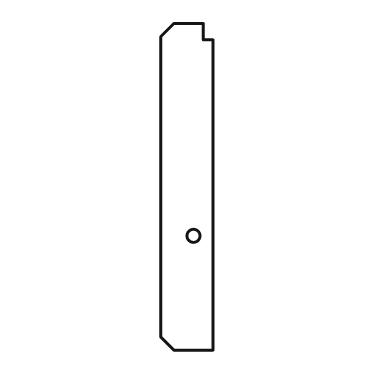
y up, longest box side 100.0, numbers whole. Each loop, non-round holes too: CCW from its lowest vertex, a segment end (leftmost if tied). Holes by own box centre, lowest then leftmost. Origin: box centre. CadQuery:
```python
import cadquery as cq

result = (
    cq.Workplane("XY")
    .moveTo(-4.0, -50.0)
    .lineTo(8.0, -50.0)
    .lineTo(8.0, 45.0)
    .lineTo(5.0, 45.0)
    .lineTo(5.0, 50.0)
    .lineTo(-4.0, 50.0)
    .lineTo(-8.0, 46.0)
    .lineTo(-8.0, -46.0)
    .close()
    .moveTo(2.0, -15.0)
    .circle(2.0)
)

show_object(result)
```